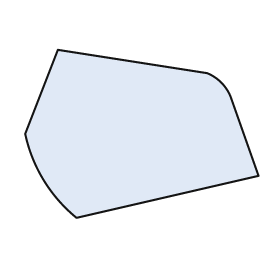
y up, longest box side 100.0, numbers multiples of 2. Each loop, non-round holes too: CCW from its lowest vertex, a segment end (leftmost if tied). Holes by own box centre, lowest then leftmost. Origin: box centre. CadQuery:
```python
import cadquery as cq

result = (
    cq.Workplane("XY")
    .moveTo(-28.0, -36.0)
    .lineTo(50.0, -18.0)
    .lineTo(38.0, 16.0)
    .threePointArc((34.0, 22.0), (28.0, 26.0))
    .lineTo(-36.0, 36.0)
    .lineTo(-50.0, 0.0)
    .threePointArc((-42.0, -20.0), (-28.0, -36.0))
    .close()
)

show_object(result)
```